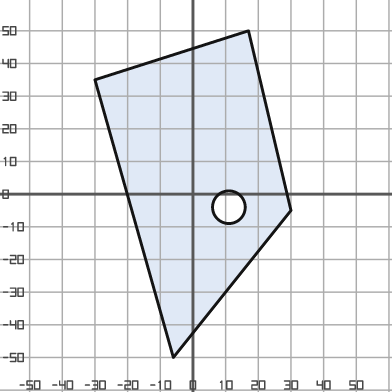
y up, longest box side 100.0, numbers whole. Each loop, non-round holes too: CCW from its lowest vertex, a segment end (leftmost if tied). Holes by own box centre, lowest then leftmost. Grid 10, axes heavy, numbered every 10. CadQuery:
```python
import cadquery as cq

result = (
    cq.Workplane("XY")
    .moveTo(-6.0, -50.0)
    .lineTo(30.0, -5.0)
    .lineTo(17.0, 50.0)
    .lineTo(-30.0, 35.0)
    .close()
    .moveTo(11.0, -4.0)
    .circle(5.0)
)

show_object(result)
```